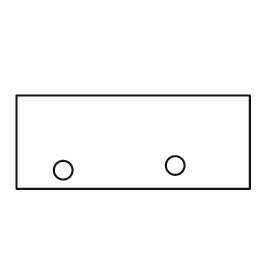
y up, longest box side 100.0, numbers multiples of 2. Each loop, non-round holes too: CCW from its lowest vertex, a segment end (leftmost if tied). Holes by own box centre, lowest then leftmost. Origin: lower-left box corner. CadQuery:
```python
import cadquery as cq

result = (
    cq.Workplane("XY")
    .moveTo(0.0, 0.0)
    .lineTo(100.0, 0.0)
    .lineTo(100.0, 40.0)
    .lineTo(0.0, 40.0)
    .close()
    .moveTo(20.0, 8.0)
    .circle(4.0)
    .moveTo(68.0, 10.0)
    .circle(4.0)
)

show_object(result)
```